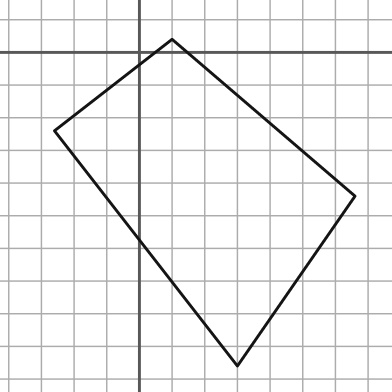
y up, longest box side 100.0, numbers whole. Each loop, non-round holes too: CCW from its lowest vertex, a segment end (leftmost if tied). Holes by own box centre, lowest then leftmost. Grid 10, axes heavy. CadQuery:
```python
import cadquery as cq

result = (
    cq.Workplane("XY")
    .moveTo(30.0, -96.0)
    .lineTo(66.0, -44.0)
    .lineTo(10.0, 4.0)
    .lineTo(-26.0, -24.0)
    .close()
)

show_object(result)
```